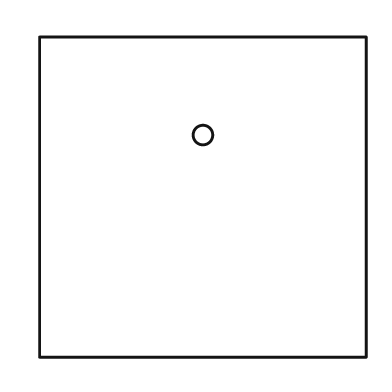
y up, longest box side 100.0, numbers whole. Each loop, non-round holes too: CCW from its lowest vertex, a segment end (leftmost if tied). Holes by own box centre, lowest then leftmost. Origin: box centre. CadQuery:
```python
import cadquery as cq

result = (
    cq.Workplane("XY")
    .moveTo(-50.0, -49.0)
    .lineTo(50.0, -49.0)
    .lineTo(50.0, 49.0)
    .lineTo(-50.0, 49.0)
    .close()
    .moveTo(0.0, 19.0)
    .circle(3.0)
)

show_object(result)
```